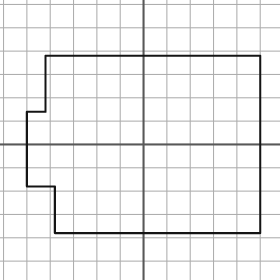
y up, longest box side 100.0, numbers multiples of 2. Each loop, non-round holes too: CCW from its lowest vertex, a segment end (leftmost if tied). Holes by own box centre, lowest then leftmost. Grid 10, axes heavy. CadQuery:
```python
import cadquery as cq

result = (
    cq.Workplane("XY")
    .moveTo(-38.0, -38.0)
    .lineTo(50.0, -38.0)
    .lineTo(50.0, 38.0)
    .lineTo(-42.0, 38.0)
    .lineTo(-42.0, 14.0)
    .lineTo(-50.0, 14.0)
    .lineTo(-50.0, -18.0)
    .lineTo(-38.0, -18.0)
    .close()
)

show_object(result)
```